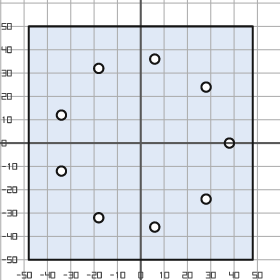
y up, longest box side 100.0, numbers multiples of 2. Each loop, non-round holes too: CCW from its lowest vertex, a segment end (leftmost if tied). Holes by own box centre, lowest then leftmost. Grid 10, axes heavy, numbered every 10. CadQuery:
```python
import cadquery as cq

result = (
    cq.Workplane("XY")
    .moveTo(-48.0, -50.0)
    .lineTo(48.0, -50.0)
    .lineTo(48.0, 50.0)
    .lineTo(-48.0, 50.0)
    .close()
    .moveTo(6.0, -36.0)
    .circle(2.0)
    .moveTo(-18.0, -32.0)
    .circle(2.0)
    .moveTo(28.0, -24.0)
    .circle(2.0)
    .moveTo(-34.0, -12.0)
    .circle(2.0)
    .moveTo(38.0, 0.0)
    .circle(2.0)
    .moveTo(-34.0, 12.0)
    .circle(2.0)
    .moveTo(28.0, 24.0)
    .circle(2.0)
    .moveTo(-18.0, 32.0)
    .circle(2.0)
    .moveTo(6.0, 36.0)
    .circle(2.0)
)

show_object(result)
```